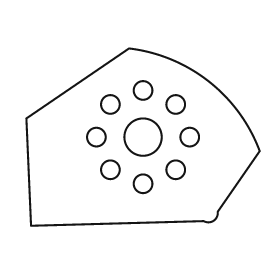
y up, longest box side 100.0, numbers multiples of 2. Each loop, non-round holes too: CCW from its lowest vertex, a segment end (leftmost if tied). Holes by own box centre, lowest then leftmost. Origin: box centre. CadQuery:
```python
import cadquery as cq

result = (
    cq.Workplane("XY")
    .moveTo(-48.0, -38.0)
    .lineTo(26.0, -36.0)
    .threePointArc((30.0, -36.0), (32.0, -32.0))
    .lineTo(50.0, -6.0)
    .threePointArc((28.0, 24.0), (-6.0, 38.0))
    .lineTo(-50.0, 8.0)
    .close()
    .moveTo(0.0, -20.0)
    .circle(4.0)
    .moveTo(-14.0, -14.0)
    .circle(4.0)
    .moveTo(14.0, -14.0)
    .circle(4.0)
    .moveTo(-20.0, 0.0)
    .circle(4.0)
    .moveTo(0.0, 0.0)
    .circle(8.0)
    .moveTo(20.0, 0.0)
    .circle(4.0)
    .moveTo(-14.0, 14.0)
    .circle(4.0)
    .moveTo(14.0, 14.0)
    .circle(4.0)
    .moveTo(0.0, 20.0)
    .circle(4.0)
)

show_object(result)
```